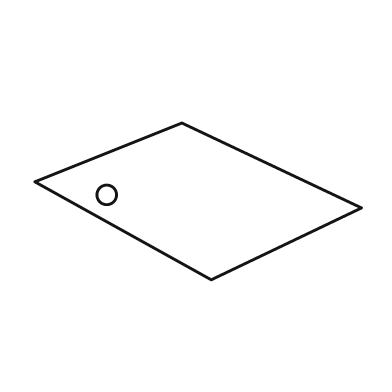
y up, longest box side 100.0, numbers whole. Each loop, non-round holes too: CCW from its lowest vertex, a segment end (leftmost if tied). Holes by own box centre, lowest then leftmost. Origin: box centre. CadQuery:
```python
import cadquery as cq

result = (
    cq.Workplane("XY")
    .moveTo(4.0, -24.0)
    .lineTo(50.0, -2.0)
    .lineTo(-5.0, 24.0)
    .lineTo(-50.0, 6.0)
    .close()
    .moveTo(-28.0, 2.0)
    .circle(3.0)
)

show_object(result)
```